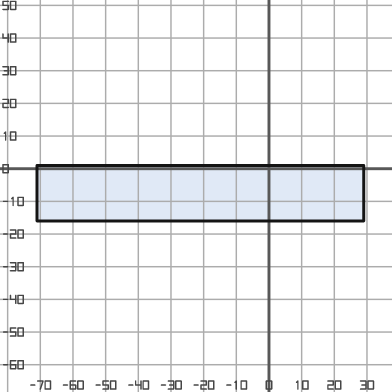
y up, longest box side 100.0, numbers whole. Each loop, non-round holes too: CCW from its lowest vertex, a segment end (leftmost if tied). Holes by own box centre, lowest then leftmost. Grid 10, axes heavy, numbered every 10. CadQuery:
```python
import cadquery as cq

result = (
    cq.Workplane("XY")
    .moveTo(-71.0, -16.0)
    .lineTo(29.0, -16.0)
    .lineTo(29.0, 1.0)
    .lineTo(-71.0, 1.0)
    .close()
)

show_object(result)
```